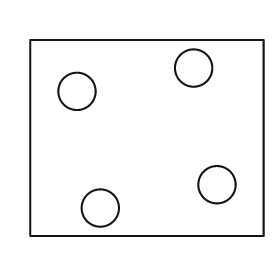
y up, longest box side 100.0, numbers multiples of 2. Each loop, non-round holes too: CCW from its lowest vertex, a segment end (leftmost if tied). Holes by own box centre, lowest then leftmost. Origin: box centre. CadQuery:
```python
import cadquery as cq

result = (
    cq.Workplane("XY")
    .moveTo(-50.0, -42.0)
    .lineTo(50.0, -42.0)
    .lineTo(50.0, 42.0)
    .lineTo(-50.0, 42.0)
    .close()
    .moveTo(-20.0, -30.0)
    .circle(8.0)
    .moveTo(30.0, -20.0)
    .circle(8.0)
    .moveTo(-30.0, 20.0)
    .circle(8.0)
    .moveTo(20.0, 30.0)
    .circle(8.0)
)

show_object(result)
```